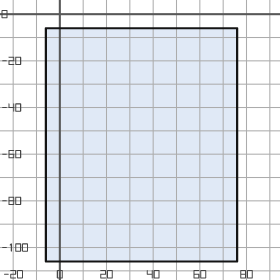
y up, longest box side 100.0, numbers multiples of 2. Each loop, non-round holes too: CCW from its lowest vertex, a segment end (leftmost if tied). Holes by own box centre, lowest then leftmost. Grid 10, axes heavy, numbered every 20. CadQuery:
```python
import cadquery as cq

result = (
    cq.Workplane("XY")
    .moveTo(-6.0, -106.0)
    .lineTo(76.0, -106.0)
    .lineTo(76.0, -6.0)
    .lineTo(-6.0, -6.0)
    .close()
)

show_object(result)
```